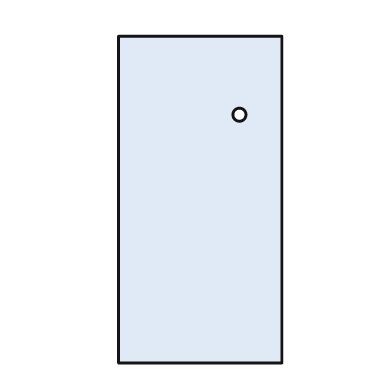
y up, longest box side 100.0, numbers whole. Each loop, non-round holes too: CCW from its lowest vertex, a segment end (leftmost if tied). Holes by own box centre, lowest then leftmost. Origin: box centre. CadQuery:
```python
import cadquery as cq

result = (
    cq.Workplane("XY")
    .moveTo(-25.0, -50.0)
    .lineTo(25.0, -50.0)
    .lineTo(25.0, 50.0)
    .lineTo(-25.0, 50.0)
    .close()
    .moveTo(12.0, 26.0)
    .circle(2.0)
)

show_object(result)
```